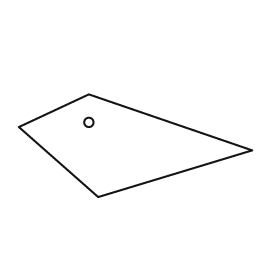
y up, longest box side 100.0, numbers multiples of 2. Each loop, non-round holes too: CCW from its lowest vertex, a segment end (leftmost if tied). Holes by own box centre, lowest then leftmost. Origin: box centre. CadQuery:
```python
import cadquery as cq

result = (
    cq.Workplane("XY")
    .moveTo(-16.0, -22.0)
    .lineTo(50.0, -2.0)
    .lineTo(-20.0, 22.0)
    .lineTo(-50.0, 8.0)
    .close()
    .moveTo(-20.0, 10.0)
    .circle(2.0)
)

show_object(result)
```